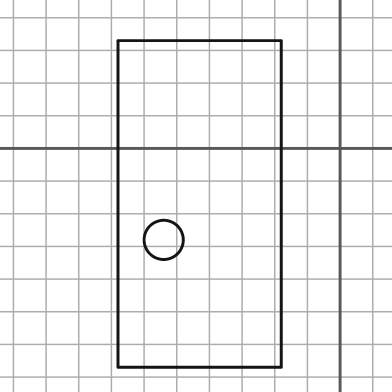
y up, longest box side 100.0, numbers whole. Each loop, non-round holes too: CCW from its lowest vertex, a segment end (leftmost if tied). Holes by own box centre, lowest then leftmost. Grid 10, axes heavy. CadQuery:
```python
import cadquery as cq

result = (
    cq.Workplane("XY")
    .moveTo(-68.0, -67.0)
    .lineTo(-18.0, -67.0)
    .lineTo(-18.0, 33.0)
    .lineTo(-68.0, 33.0)
    .close()
    .moveTo(-54.0, -28.0)
    .circle(6.0)
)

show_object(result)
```